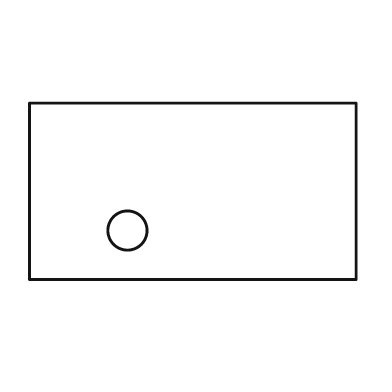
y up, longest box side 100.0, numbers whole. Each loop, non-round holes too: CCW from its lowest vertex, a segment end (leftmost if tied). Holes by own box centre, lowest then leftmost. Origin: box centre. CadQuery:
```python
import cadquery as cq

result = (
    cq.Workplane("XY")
    .moveTo(-50.0, -27.0)
    .lineTo(50.0, -27.0)
    .lineTo(50.0, 27.0)
    .lineTo(-50.0, 27.0)
    .close()
    .moveTo(-20.0, -12.0)
    .circle(6.0)
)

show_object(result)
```